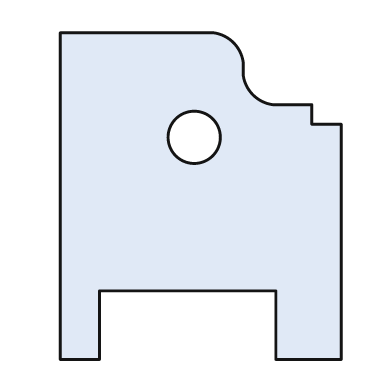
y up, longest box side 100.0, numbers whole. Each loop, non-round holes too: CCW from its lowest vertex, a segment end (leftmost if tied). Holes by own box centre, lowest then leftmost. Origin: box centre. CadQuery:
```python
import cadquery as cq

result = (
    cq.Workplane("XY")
    .moveTo(-43.0, -50.0)
    .lineTo(-31.0, -50.0)
    .lineTo(-31.0, -29.0)
    .lineTo(23.0, -29.0)
    .lineTo(23.0, -50.0)
    .lineTo(43.0, -50.0)
    .lineTo(43.0, 22.0)
    .lineTo(34.0, 22.0)
    .lineTo(34.0, 28.0)
    .lineTo(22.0, 28.0)
    .threePointArc((16.0, 31.0), (13.0, 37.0))
    .lineTo(13.0, 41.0)
    .threePointArc((10.0, 47.0), (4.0, 50.0))
    .lineTo(-43.0, 50.0)
    .close()
    .moveTo(-2.0, 18.0)
    .circle(8.0)
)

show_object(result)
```